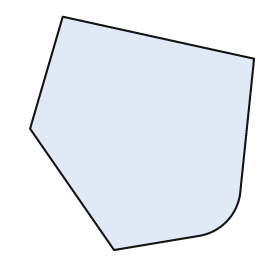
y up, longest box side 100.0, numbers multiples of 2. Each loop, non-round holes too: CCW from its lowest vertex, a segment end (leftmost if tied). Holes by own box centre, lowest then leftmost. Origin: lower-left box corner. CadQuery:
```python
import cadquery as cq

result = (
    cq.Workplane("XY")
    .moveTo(36.0, 0.0)
    .lineTo(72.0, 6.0)
    .threePointArc((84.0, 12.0), (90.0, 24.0))
    .lineTo(96.0, 82.0)
    .lineTo(14.0, 100.0)
    .lineTo(0.0, 52.0)
    .close()
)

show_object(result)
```